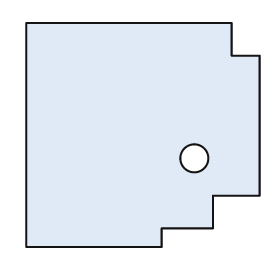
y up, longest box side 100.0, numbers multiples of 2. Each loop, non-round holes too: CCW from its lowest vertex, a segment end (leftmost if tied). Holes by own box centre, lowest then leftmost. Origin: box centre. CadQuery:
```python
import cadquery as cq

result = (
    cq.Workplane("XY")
    .moveTo(-50.0, -48.0)
    .lineTo(8.0, -48.0)
    .lineTo(8.0, -40.0)
    .lineTo(30.0, -40.0)
    .lineTo(30.0, -26.0)
    .lineTo(50.0, -26.0)
    .lineTo(50.0, 34.0)
    .lineTo(38.0, 34.0)
    .lineTo(38.0, 48.0)
    .lineTo(-50.0, 48.0)
    .close()
    .moveTo(22.0, -10.0)
    .circle(6.0)
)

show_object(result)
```